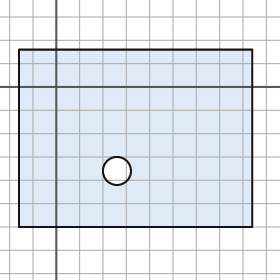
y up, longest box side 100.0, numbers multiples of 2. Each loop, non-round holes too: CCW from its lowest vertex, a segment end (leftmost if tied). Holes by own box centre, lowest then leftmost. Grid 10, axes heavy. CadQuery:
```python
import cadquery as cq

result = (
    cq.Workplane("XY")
    .moveTo(-16.0, -60.0)
    .lineTo(84.0, -60.0)
    .lineTo(84.0, 16.0)
    .lineTo(-16.0, 16.0)
    .close()
    .moveTo(26.0, -36.0)
    .circle(6.0)
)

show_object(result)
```